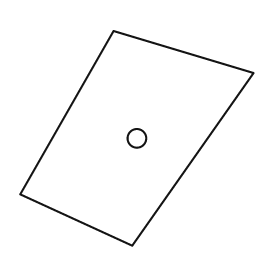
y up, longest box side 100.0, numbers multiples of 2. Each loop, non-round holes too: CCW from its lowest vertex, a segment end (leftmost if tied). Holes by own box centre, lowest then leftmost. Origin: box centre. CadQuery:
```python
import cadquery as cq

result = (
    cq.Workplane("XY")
    .moveTo(-2.0, -46.0)
    .lineTo(50.0, 28.0)
    .lineTo(-10.0, 46.0)
    .lineTo(-50.0, -24.0)
    .close()
    .moveTo(0.0, 0.0)
    .circle(4.0)
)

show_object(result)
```